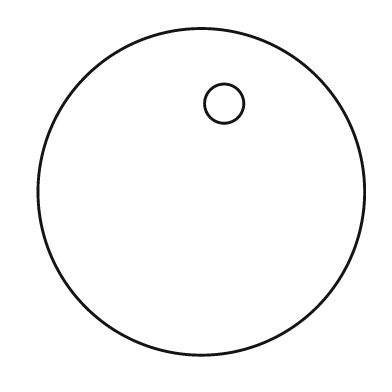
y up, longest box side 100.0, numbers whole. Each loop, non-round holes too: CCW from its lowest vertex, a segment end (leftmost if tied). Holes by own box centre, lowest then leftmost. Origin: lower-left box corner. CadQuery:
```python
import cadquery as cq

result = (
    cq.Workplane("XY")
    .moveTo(50.0, 50.0)
    .circle(50.0)
    .moveTo(57.0, 77.0)
    .circle(6.0)
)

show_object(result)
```